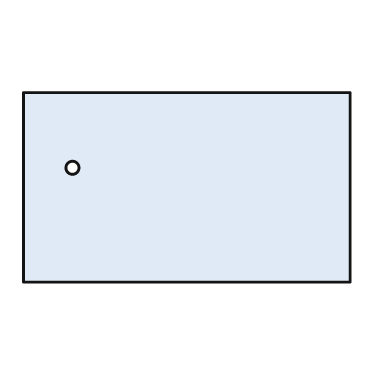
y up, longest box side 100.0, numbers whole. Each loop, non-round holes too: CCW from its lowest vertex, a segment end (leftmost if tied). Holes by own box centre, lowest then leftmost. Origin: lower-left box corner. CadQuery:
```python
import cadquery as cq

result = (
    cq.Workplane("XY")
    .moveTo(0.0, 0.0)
    .lineTo(100.0, 0.0)
    .lineTo(100.0, 58.0)
    .lineTo(0.0, 58.0)
    .close()
    .moveTo(15.0, 35.0)
    .circle(2.0)
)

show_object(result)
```